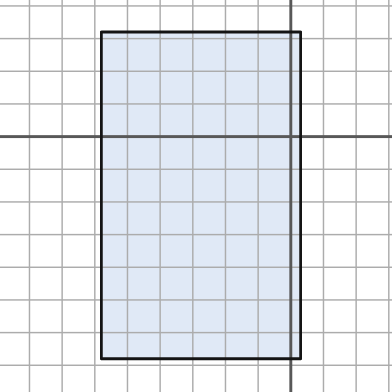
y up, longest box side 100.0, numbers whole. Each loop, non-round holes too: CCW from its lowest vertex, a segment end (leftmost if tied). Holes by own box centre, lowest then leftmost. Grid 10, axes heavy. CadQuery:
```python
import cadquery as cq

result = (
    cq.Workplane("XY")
    .moveTo(-58.0, -68.0)
    .lineTo(3.0, -68.0)
    .lineTo(3.0, 32.0)
    .lineTo(-58.0, 32.0)
    .close()
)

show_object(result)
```